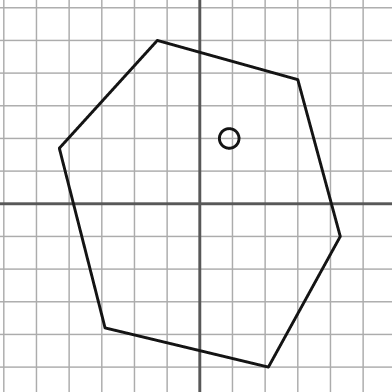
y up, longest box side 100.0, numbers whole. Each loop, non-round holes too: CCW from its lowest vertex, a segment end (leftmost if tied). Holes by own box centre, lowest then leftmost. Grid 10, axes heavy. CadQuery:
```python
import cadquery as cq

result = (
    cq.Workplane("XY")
    .moveTo(21.0, -50.0)
    .lineTo(43.0, -10.0)
    .lineTo(30.0, 38.0)
    .lineTo(-13.0, 50.0)
    .lineTo(-43.0, 17.0)
    .lineTo(-29.0, -38.0)
    .close()
    .moveTo(9.0, 20.0)
    .circle(3.0)
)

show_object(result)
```